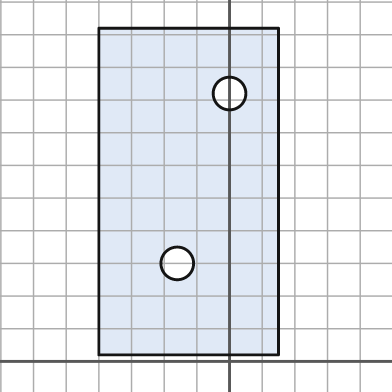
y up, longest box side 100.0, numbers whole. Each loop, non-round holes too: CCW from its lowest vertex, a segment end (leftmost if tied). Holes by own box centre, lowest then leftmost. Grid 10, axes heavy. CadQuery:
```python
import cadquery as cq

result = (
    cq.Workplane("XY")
    .moveTo(-40.0, 2.0)
    .lineTo(15.0, 2.0)
    .lineTo(15.0, 102.0)
    .lineTo(-40.0, 102.0)
    .close()
    .moveTo(-16.0, 30.0)
    .circle(5.0)
    .moveTo(0.0, 82.0)
    .circle(5.0)
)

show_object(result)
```